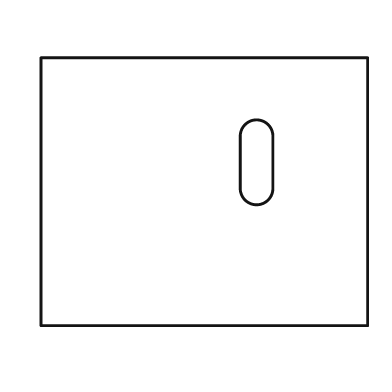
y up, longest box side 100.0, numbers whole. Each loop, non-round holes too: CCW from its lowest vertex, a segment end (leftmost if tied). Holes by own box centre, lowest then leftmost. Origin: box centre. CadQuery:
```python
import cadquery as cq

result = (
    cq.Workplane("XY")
    .moveTo(-50.0, -41.0)
    .lineTo(50.0, -41.0)
    .lineTo(50.0, 41.0)
    .lineTo(-50.0, 41.0)
    .close()
    .moveTo(11.0, 1.0)
    .threePointArc((16.0, -4.0), (21.0, 1.0))
    .lineTo(21.0, 17.0)
    .threePointArc((16.0, 22.0), (11.0, 17.0))
    .close()
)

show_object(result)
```